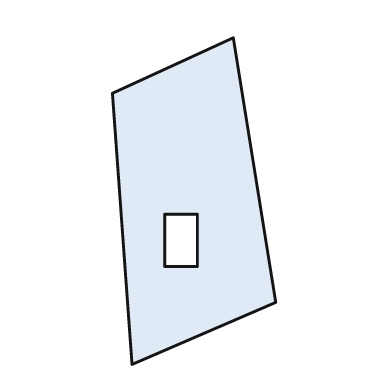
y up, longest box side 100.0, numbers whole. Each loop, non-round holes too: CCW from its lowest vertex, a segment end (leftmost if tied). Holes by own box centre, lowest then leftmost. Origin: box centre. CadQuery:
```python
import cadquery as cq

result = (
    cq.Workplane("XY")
    .moveTo(-19.0, -50.0)
    .lineTo(25.0, -31.0)
    .lineTo(12.0, 50.0)
    .lineTo(-25.0, 33.0)
    .close()
    .moveTo(-9.0, -20.0)
    .lineTo(1.0, -20.0)
    .lineTo(1.0, -4.0)
    .lineTo(-9.0, -4.0)
    .close()
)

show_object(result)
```